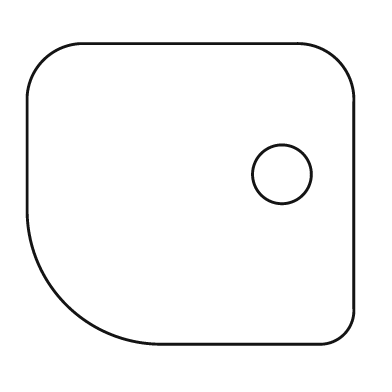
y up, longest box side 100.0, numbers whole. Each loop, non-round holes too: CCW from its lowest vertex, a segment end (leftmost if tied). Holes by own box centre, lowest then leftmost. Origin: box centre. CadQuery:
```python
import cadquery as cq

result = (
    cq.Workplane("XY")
    .moveTo(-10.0, -46.0)
    .lineTo(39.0, -46.0)
    .threePointArc((47.0, -43.0), (50.0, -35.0))
    .lineTo(50.0, 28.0)
    .threePointArc((45.0, 41.0), (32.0, 46.0))
    .lineTo(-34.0, 46.0)
    .threePointArc((-45.0, 41.0), (-50.0, 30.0))
    .lineTo(-50.0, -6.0)
    .threePointArc((-38.0, -34.0), (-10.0, -46.0))
    .close()
    .moveTo(28.0, 6.0)
    .circle(9.0)
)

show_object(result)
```